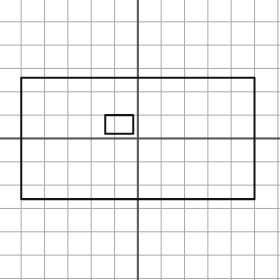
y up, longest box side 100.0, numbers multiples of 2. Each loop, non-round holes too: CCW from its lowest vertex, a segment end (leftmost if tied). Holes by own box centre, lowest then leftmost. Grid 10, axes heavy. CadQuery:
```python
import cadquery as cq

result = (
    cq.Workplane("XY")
    .moveTo(-50.0, -26.0)
    .lineTo(50.0, -26.0)
    .lineTo(50.0, 26.0)
    .lineTo(-50.0, 26.0)
    .close()
    .moveTo(-14.0, 2.0)
    .lineTo(-2.0, 2.0)
    .lineTo(-2.0, 10.0)
    .lineTo(-14.0, 10.0)
    .close()
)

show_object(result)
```